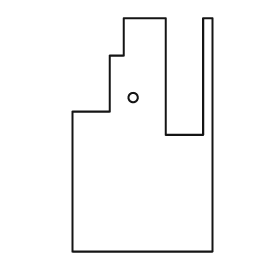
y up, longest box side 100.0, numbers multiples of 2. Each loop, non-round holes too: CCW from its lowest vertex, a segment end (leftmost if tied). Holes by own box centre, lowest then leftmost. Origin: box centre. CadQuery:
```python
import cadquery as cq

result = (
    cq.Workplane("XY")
    .moveTo(-30.0, -50.0)
    .lineTo(30.0, -50.0)
    .lineTo(30.0, 50.0)
    .lineTo(26.0, 50.0)
    .lineTo(26.0, 0.0)
    .lineTo(10.0, 0.0)
    .lineTo(10.0, 50.0)
    .lineTo(-8.0, 50.0)
    .lineTo(-8.0, 34.0)
    .lineTo(-14.0, 34.0)
    .lineTo(-14.0, 10.0)
    .lineTo(-30.0, 10.0)
    .close()
    .moveTo(-4.0, 16.0)
    .circle(2.0)
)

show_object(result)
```